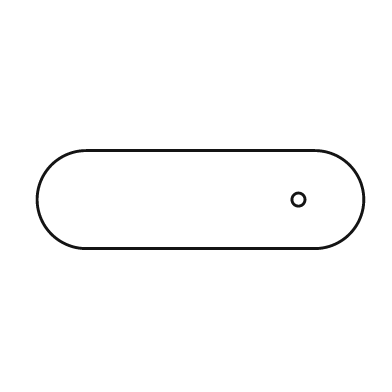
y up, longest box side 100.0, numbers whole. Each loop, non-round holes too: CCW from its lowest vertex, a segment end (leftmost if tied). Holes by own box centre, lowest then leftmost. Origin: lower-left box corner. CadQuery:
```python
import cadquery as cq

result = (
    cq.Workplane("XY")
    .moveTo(15.0, 0.0)
    .lineTo(85.0, 0.0)
    .threePointArc((100.0, 15.0), (85.0, 30.0))
    .lineTo(15.0, 30.0)
    .threePointArc((0.0, 15.0), (15.0, 0.0))
    .close()
    .moveTo(80.0, 15.0)
    .circle(2.0)
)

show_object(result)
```